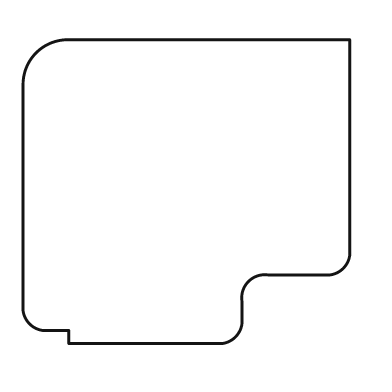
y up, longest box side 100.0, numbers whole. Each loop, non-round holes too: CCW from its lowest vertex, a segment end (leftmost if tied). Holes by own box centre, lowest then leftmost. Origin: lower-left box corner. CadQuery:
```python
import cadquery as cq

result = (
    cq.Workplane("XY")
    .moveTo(14.0, 0.0)
    .lineTo(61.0, 0.0)
    .threePointArc((65.0, 2.0), (67.0, 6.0))
    .lineTo(67.0, 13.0)
    .threePointArc((69.0, 19.0), (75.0, 21.0))
    .lineTo(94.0, 21.0)
    .threePointArc((98.0, 23.0), (100.0, 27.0))
    .lineTo(100.0, 93.0)
    .lineTo(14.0, 93.0)
    .threePointArc((4.0, 89.0), (0.0, 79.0))
    .lineTo(0.0, 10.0)
    .threePointArc((2.0, 6.0), (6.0, 4.0))
    .lineTo(14.0, 4.0)
    .close()
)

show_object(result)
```